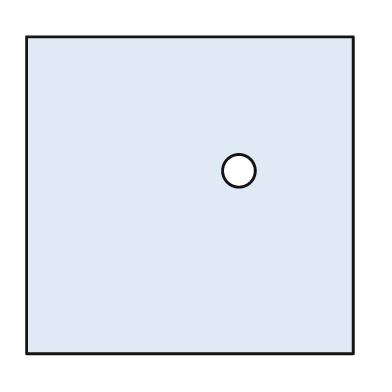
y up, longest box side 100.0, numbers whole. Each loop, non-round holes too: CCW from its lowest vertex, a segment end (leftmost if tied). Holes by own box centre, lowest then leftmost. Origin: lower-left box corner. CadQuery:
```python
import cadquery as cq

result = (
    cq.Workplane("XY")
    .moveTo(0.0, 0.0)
    .lineTo(100.0, 0.0)
    .lineTo(100.0, 97.0)
    .lineTo(0.0, 97.0)
    .close()
    .moveTo(65.0, 56.0)
    .circle(5.0)
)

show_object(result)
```